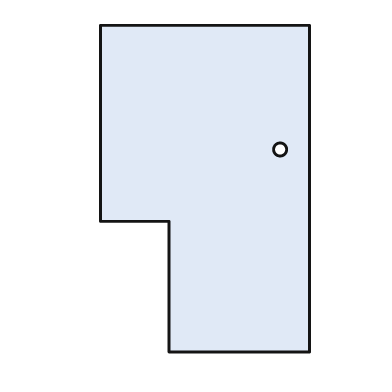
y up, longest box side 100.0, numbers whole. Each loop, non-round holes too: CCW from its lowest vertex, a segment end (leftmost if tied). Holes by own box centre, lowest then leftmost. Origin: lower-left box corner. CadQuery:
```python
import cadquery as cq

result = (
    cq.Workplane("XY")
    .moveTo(21.0, 0.0)
    .lineTo(64.0, 0.0)
    .lineTo(64.0, 100.0)
    .lineTo(0.0, 100.0)
    .lineTo(0.0, 40.0)
    .lineTo(21.0, 40.0)
    .close()
    .moveTo(55.0, 62.0)
    .circle(2.0)
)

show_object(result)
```